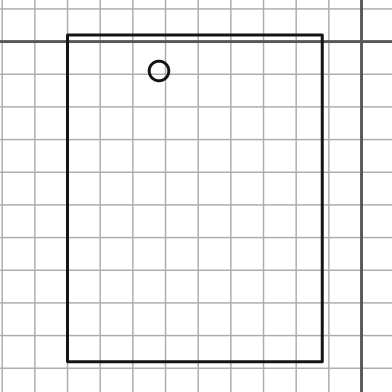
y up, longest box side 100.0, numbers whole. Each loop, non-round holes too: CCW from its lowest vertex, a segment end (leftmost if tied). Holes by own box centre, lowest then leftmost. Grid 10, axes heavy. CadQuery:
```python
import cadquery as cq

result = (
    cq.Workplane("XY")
    .moveTo(-90.0, -98.0)
    .lineTo(-12.0, -98.0)
    .lineTo(-12.0, 2.0)
    .lineTo(-90.0, 2.0)
    .close()
    .moveTo(-62.0, -9.0)
    .circle(3.0)
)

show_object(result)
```